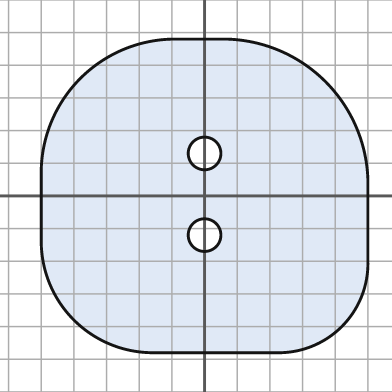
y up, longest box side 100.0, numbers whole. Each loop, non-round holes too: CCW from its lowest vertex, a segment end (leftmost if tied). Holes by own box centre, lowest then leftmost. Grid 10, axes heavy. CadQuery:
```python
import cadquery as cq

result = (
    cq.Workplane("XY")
    .moveTo(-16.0, -48.0)
    .lineTo(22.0, -48.0)
    .threePointArc((42.0, -40.0), (50.0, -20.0))
    .lineTo(50.0, 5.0)
    .threePointArc((37.0, 35.0), (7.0, 48.0))
    .lineTo(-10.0, 48.0)
    .threePointArc((-38.0, 36.0), (-50.0, 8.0))
    .lineTo(-50.0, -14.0)
    .threePointArc((-40.0, -38.0), (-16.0, -48.0))
    .close()
    .moveTo(0.0, -12.0)
    .circle(5.0)
    .moveTo(0.0, 13.0)
    .circle(5.0)
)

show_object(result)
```